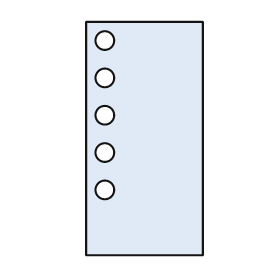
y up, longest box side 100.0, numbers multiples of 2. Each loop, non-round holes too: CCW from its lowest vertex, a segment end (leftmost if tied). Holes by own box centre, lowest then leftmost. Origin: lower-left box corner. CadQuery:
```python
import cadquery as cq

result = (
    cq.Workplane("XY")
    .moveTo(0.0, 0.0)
    .lineTo(50.0, 0.0)
    .lineTo(50.0, 100.0)
    .lineTo(0.0, 100.0)
    .close()
    .moveTo(8.0, 28.0)
    .circle(4.0)
    .moveTo(8.0, 44.0)
    .circle(4.0)
    .moveTo(8.0, 60.0)
    .circle(4.0)
    .moveTo(8.0, 76.0)
    .circle(4.0)
    .moveTo(8.0, 92.0)
    .circle(4.0)
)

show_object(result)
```